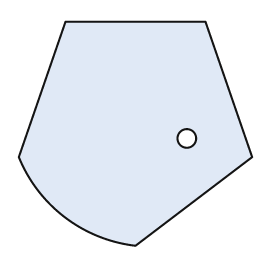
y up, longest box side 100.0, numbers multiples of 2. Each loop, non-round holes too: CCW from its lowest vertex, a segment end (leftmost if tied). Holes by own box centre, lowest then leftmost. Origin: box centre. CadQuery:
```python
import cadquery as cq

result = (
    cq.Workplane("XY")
    .moveTo(0.0, -48.0)
    .lineTo(50.0, -10.0)
    .lineTo(30.0, 48.0)
    .lineTo(-30.0, 48.0)
    .lineTo(-50.0, -10.0)
    .threePointArc((-30.0, -36.0), (0.0, -48.0))
    .close()
    .moveTo(22.0, -2.0)
    .circle(4.0)
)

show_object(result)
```